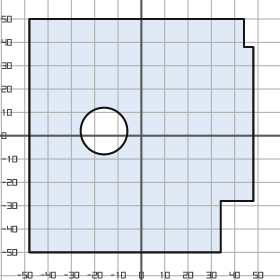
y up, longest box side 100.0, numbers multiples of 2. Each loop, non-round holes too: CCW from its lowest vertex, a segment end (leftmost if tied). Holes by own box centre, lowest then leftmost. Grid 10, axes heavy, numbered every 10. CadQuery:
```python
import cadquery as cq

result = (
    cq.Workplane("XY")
    .moveTo(-48.0, -50.0)
    .lineTo(34.0, -50.0)
    .lineTo(34.0, -28.0)
    .lineTo(48.0, -28.0)
    .lineTo(48.0, 38.0)
    .lineTo(44.0, 38.0)
    .lineTo(44.0, 50.0)
    .lineTo(-48.0, 50.0)
    .close()
    .moveTo(-16.0, 2.0)
    .circle(10.0)
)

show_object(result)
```